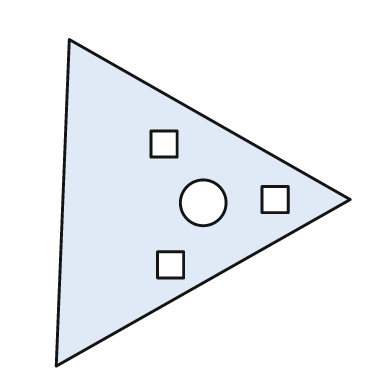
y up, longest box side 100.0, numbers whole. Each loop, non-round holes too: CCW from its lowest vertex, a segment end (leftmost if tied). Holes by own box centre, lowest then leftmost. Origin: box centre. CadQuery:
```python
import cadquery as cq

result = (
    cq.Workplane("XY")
    .moveTo(-45.0, -50.0)
    .lineTo(45.0, 1.0)
    .lineTo(-41.0, 50.0)
    .close()
    .moveTo(-14.0, -23.0)
    .lineTo(-6.0, -23.0)
    .lineTo(-6.0, -15.0)
    .lineTo(-14.0, -15.0)
    .close()
    .moveTo(0.0, 0.0)
    .circle(7.0)
    .moveTo(18.0, -3.0)
    .lineTo(26.0, -3.0)
    .lineTo(26.0, 5.0)
    .lineTo(18.0, 5.0)
    .close()
    .moveTo(-16.0, 14.0)
    .lineTo(-8.0, 14.0)
    .lineTo(-8.0, 22.0)
    .lineTo(-16.0, 22.0)
    .close()
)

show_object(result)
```